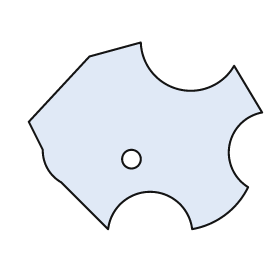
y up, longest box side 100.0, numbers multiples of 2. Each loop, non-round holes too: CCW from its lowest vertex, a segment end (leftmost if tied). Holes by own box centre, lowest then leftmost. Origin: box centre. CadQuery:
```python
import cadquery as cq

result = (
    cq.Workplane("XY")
    .moveTo(-16.0, -40.0)
    .threePointArc((2.0, -24.0), (20.0, -40.0))
    .threePointArc((34.0, -34.0), (44.0, -22.0))
    .threePointArc((36.0, -4.0), (50.0, 10.0))
    .lineTo(38.0, 30.0)
    .threePointArc((14.0, 20.0), (-2.0, 40.0))
    .lineTo(-24.0, 34.0)
    .lineTo(-50.0, 6.0)
    .lineTo(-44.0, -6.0)
    .threePointArc((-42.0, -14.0), (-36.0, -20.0))
    .close()
    .moveTo(-6.0, -10.0)
    .circle(4.0)
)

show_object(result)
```